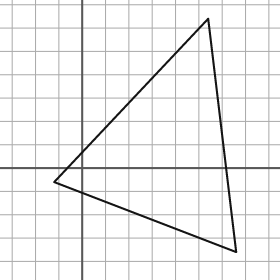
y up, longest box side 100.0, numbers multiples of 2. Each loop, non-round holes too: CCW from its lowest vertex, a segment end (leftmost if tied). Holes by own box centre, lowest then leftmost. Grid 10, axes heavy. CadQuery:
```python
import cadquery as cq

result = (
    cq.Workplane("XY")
    .moveTo(66.0, -36.0)
    .lineTo(54.0, 64.0)
    .lineTo(-12.0, -6.0)
    .close()
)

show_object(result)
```